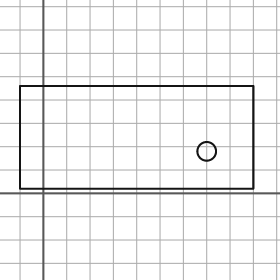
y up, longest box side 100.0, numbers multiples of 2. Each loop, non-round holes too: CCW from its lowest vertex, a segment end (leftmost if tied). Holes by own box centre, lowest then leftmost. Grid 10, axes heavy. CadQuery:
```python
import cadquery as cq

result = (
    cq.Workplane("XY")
    .moveTo(-10.0, 2.0)
    .lineTo(90.0, 2.0)
    .lineTo(90.0, 46.0)
    .lineTo(-10.0, 46.0)
    .close()
    .moveTo(70.0, 18.0)
    .circle(4.0)
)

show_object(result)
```